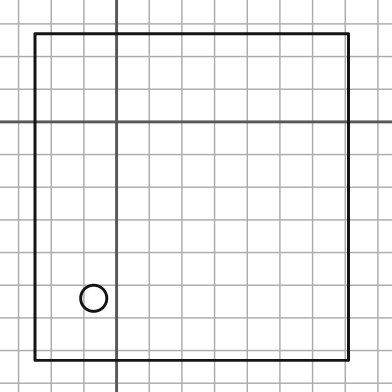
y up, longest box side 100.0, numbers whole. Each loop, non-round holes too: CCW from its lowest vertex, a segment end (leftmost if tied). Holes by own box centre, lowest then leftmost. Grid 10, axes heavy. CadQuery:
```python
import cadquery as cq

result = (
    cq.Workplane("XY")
    .moveTo(-25.0, -73.0)
    .lineTo(71.0, -73.0)
    .lineTo(71.0, 27.0)
    .lineTo(-25.0, 27.0)
    .close()
    .moveTo(-7.0, -54.0)
    .circle(4.0)
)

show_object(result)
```